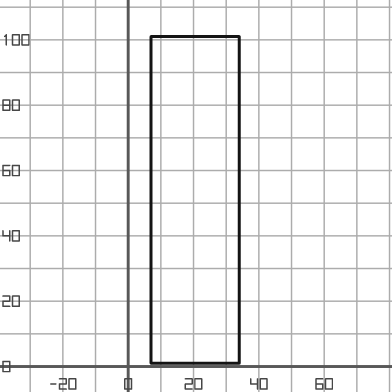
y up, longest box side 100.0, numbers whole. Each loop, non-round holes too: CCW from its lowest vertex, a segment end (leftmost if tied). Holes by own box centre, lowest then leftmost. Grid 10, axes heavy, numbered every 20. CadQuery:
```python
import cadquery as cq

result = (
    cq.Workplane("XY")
    .moveTo(7.0, 1.0)
    .lineTo(34.0, 1.0)
    .lineTo(34.0, 101.0)
    .lineTo(7.0, 101.0)
    .close()
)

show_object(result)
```